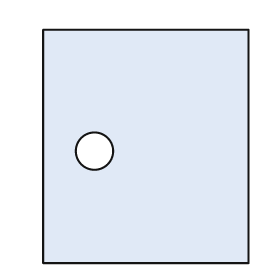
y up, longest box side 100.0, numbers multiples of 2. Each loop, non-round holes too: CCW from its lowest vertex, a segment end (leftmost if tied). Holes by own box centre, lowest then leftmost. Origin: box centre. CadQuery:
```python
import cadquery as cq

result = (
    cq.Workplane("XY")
    .moveTo(-44.0, -50.0)
    .lineTo(44.0, -50.0)
    .lineTo(44.0, 50.0)
    .lineTo(-44.0, 50.0)
    .close()
    .moveTo(-22.0, -2.0)
    .circle(8.0)
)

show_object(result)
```